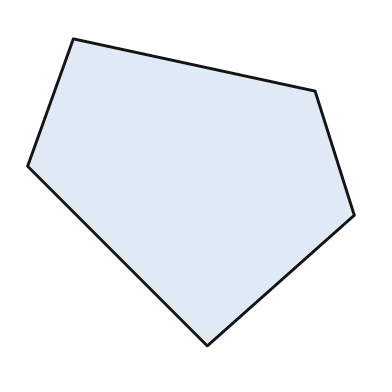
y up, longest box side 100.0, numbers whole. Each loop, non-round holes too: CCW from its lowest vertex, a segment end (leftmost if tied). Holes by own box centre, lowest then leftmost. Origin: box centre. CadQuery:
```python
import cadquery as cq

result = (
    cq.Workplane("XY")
    .moveTo(5.0, -47.0)
    .lineTo(50.0, -7.0)
    .lineTo(38.0, 31.0)
    .lineTo(-36.0, 47.0)
    .lineTo(-50.0, 8.0)
    .close()
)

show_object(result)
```